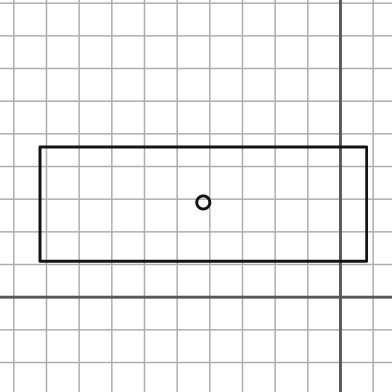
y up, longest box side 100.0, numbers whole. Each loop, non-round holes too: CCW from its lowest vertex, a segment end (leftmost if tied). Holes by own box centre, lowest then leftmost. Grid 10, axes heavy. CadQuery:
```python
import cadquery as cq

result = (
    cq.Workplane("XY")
    .moveTo(-92.0, 11.0)
    .lineTo(8.0, 11.0)
    .lineTo(8.0, 46.0)
    .lineTo(-92.0, 46.0)
    .close()
    .moveTo(-42.0, 29.0)
    .circle(2.0)
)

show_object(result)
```